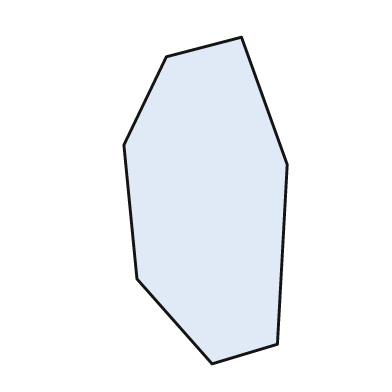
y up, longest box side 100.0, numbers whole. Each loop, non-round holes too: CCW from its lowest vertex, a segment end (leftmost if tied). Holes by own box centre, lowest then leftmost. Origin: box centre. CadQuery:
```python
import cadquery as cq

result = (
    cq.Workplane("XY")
    .moveTo(2.0, -50.0)
    .lineTo(22.0, -44.0)
    .lineTo(25.0, 11.0)
    .lineTo(11.0, 50.0)
    .lineTo(-12.0, 44.0)
    .lineTo(-25.0, 17.0)
    .lineTo(-21.0, -24.0)
    .close()
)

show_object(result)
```